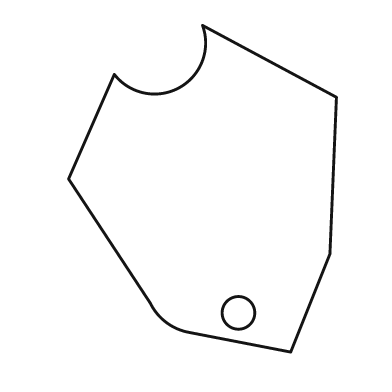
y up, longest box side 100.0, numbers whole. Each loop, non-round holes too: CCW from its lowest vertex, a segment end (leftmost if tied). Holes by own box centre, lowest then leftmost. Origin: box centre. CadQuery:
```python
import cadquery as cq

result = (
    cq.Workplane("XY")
    .moveTo(27.0, -50.0)
    .lineTo(39.0, -20.0)
    .lineTo(41.0, 28.0)
    .lineTo(0.0, 50.0)
    .threePointArc((-7.0, 31.0), (-27.0, 35.0))
    .lineTo(-41.0, 3.0)
    .lineTo(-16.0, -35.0)
    .threePointArc((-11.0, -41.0), (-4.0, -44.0))
    .close()
    .moveTo(11.0, -38.0)
    .circle(5.0)
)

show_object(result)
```